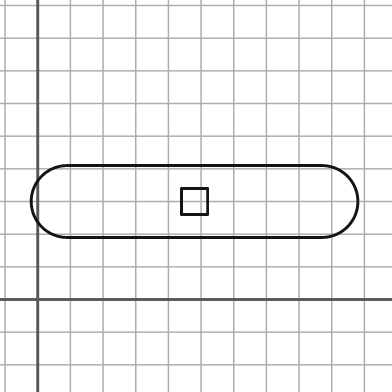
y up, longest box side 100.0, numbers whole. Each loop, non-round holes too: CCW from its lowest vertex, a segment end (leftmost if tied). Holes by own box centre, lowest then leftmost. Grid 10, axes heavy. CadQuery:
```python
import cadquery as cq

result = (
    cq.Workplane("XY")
    .moveTo(9.0, 19.0)
    .lineTo(87.0, 19.0)
    .threePointArc((98.0, 30.0), (87.0, 41.0))
    .lineTo(9.0, 41.0)
    .threePointArc((-2.0, 30.0), (9.0, 19.0))
    .close()
    .moveTo(44.0, 26.0)
    .lineTo(52.0, 26.0)
    .lineTo(52.0, 34.0)
    .lineTo(44.0, 34.0)
    .close()
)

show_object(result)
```